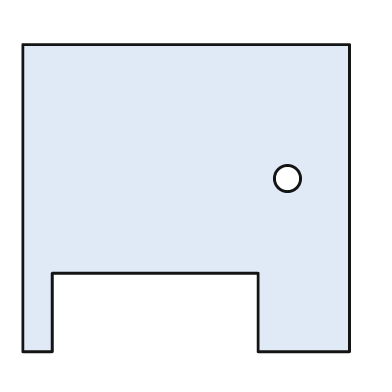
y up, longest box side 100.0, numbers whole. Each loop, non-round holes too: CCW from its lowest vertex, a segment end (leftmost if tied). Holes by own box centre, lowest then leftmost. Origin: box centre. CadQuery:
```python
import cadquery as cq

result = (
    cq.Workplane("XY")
    .moveTo(-50.0, -47.0)
    .lineTo(-41.0, -47.0)
    .lineTo(-41.0, -23.0)
    .lineTo(22.0, -23.0)
    .lineTo(22.0, -47.0)
    .lineTo(50.0, -47.0)
    .lineTo(50.0, 47.0)
    .lineTo(-50.0, 47.0)
    .close()
    .moveTo(31.0, 6.0)
    .circle(4.0)
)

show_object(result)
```